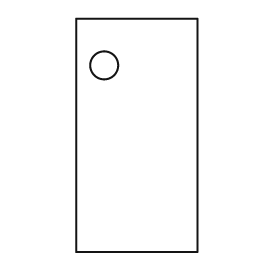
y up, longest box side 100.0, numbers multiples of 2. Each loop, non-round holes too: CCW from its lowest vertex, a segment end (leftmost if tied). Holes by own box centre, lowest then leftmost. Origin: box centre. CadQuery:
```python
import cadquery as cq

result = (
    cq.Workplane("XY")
    .moveTo(-26.0, -50.0)
    .lineTo(26.0, -50.0)
    .lineTo(26.0, 50.0)
    .lineTo(-26.0, 50.0)
    .close()
    .moveTo(-14.0, 30.0)
    .circle(6.0)
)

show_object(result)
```